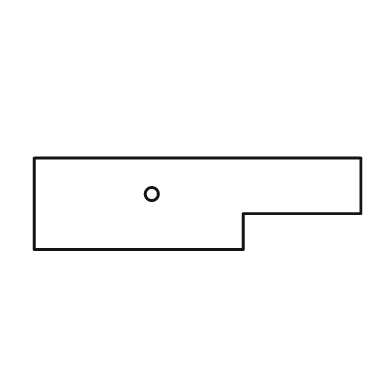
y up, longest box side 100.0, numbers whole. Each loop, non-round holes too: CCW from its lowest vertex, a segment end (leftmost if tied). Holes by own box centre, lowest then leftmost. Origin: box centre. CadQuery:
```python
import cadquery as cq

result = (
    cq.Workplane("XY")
    .moveTo(-50.0, -14.0)
    .lineTo(14.0, -14.0)
    .lineTo(14.0, -3.0)
    .lineTo(50.0, -3.0)
    .lineTo(50.0, 14.0)
    .lineTo(-50.0, 14.0)
    .close()
    .moveTo(-14.0, 3.0)
    .circle(2.0)
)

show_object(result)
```